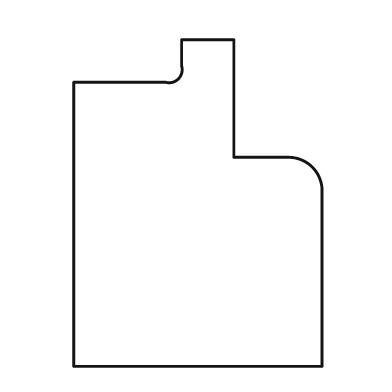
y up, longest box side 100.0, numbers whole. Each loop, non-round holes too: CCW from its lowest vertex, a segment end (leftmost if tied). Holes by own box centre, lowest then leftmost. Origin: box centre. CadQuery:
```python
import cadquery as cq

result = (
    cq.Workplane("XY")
    .moveTo(-38.0, -50.0)
    .lineTo(38.0, -50.0)
    .lineTo(38.0, 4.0)
    .threePointArc((35.0, 11.0), (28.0, 14.0))
    .lineTo(11.0, 14.0)
    .lineTo(11.0, 50.0)
    .lineTo(-5.0, 50.0)
    .lineTo(-5.0, 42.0)
    .threePointArc((-6.0, 38.0), (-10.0, 37.0))
    .lineTo(-38.0, 37.0)
    .close()
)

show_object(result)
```